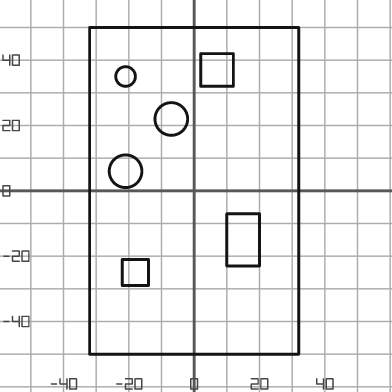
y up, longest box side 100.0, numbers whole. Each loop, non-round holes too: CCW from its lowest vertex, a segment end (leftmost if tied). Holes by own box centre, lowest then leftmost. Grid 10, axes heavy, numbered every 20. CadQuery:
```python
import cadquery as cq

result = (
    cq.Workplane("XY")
    .moveTo(-32.0, -50.0)
    .lineTo(32.0, -50.0)
    .lineTo(32.0, 50.0)
    .lineTo(-32.0, 50.0)
    .close()
    .moveTo(-22.0, -29.0)
    .lineTo(-14.0, -29.0)
    .lineTo(-14.0, -21.0)
    .lineTo(-22.0, -21.0)
    .close()
    .moveTo(10.0, -23.0)
    .lineTo(20.0, -23.0)
    .lineTo(20.0, -7.0)
    .lineTo(10.0, -7.0)
    .close()
    .moveTo(-21.0, 6.0)
    .circle(5.0)
    .moveTo(-7.0, 22.0)
    .circle(5.0)
    .moveTo(-21.0, 35.0)
    .circle(3.0)
    .moveTo(2.0, 32.0)
    .lineTo(12.0, 32.0)
    .lineTo(12.0, 42.0)
    .lineTo(2.0, 42.0)
    .close()
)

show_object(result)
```